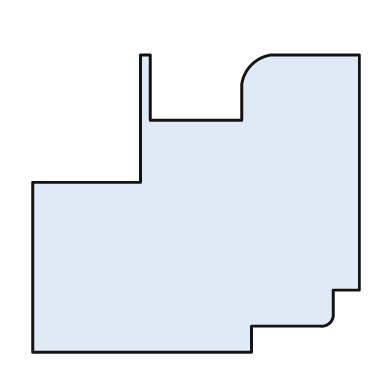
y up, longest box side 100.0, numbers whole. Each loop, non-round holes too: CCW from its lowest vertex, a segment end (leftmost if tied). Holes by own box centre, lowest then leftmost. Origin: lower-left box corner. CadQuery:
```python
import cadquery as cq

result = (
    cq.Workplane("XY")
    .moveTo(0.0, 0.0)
    .lineTo(67.0, 0.0)
    .lineTo(67.0, 8.0)
    .lineTo(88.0, 8.0)
    .threePointArc((91.0, 9.0), (92.0, 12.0))
    .lineTo(92.0, 19.0)
    .lineTo(100.0, 19.0)
    .lineTo(100.0, 91.0)
    .lineTo(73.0, 91.0)
    .threePointArc((67.0, 88.0), (64.0, 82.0))
    .lineTo(64.0, 71.0)
    .lineTo(36.0, 71.0)
    .lineTo(36.0, 91.0)
    .lineTo(33.0, 91.0)
    .lineTo(33.0, 52.0)
    .lineTo(0.0, 52.0)
    .close()
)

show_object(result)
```